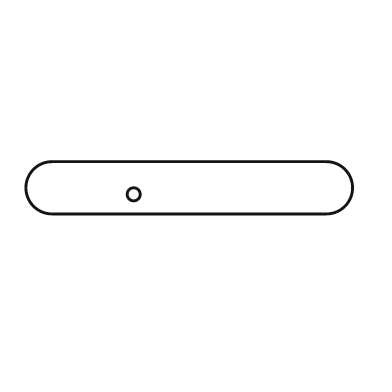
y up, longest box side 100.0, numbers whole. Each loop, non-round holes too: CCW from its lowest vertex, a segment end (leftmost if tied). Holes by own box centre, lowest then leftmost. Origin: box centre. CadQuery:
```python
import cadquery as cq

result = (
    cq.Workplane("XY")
    .moveTo(-42.0, -8.0)
    .lineTo(42.0, -8.0)
    .threePointArc((50.0, 0.0), (42.0, 8.0))
    .lineTo(-42.0, 8.0)
    .threePointArc((-50.0, 0.0), (-42.0, -8.0))
    .close()
    .moveTo(-17.0, -2.0)
    .circle(2.0)
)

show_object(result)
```